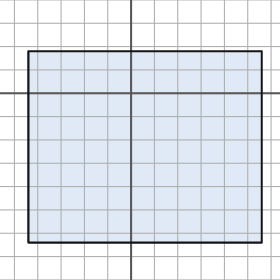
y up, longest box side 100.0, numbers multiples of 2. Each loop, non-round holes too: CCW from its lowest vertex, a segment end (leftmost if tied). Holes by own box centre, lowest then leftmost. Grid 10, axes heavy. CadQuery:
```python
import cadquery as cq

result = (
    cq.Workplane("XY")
    .moveTo(-44.0, -64.0)
    .lineTo(56.0, -64.0)
    .lineTo(56.0, 18.0)
    .lineTo(-44.0, 18.0)
    .close()
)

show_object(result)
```